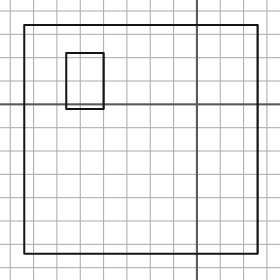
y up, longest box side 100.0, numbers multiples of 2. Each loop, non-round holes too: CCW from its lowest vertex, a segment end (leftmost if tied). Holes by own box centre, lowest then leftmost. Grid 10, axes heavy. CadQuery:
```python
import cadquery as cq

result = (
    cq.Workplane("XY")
    .moveTo(-74.0, -64.0)
    .lineTo(26.0, -64.0)
    .lineTo(26.0, 34.0)
    .lineTo(-74.0, 34.0)
    .close()
    .moveTo(-56.0, -2.0)
    .lineTo(-40.0, -2.0)
    .lineTo(-40.0, 22.0)
    .lineTo(-56.0, 22.0)
    .close()
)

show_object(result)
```